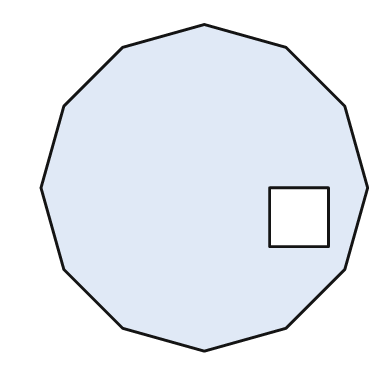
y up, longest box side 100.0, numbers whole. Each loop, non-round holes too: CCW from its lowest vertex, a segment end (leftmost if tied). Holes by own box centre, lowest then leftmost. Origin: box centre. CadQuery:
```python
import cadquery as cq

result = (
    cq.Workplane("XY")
    .moveTo(0.0, -50.0)
    .lineTo(25.0, -43.0)
    .lineTo(43.0, -25.0)
    .lineTo(50.0, 0.0)
    .lineTo(43.0, 25.0)
    .lineTo(25.0, 43.0)
    .lineTo(0.0, 50.0)
    .lineTo(-25.0, 43.0)
    .lineTo(-43.0, 25.0)
    .lineTo(-50.0, 0.0)
    .lineTo(-43.0, -25.0)
    .lineTo(-25.0, -43.0)
    .close()
    .moveTo(20.0, -18.0)
    .lineTo(38.0, -18.0)
    .lineTo(38.0, 0.0)
    .lineTo(20.0, 0.0)
    .close()
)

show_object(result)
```